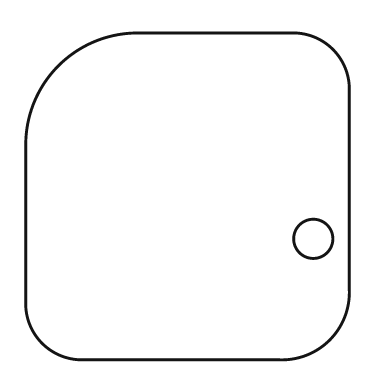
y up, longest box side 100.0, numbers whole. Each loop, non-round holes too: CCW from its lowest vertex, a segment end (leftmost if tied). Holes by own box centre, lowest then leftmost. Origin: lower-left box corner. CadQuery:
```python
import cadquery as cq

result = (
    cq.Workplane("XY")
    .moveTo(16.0, 0.0)
    .lineTo(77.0, 0.0)
    .threePointArc((93.0, 6.0), (99.0, 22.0))
    .lineTo(99.0, 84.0)
    .threePointArc((94.0, 95.0), (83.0, 100.0))
    .lineTo(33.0, 100.0)
    .threePointArc((10.0, 90.0), (0.0, 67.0))
    .lineTo(0.0, 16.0)
    .threePointArc((5.0, 5.0), (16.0, 0.0))
    .close()
    .moveTo(88.0, 37.0)
    .circle(6.0)
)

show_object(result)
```